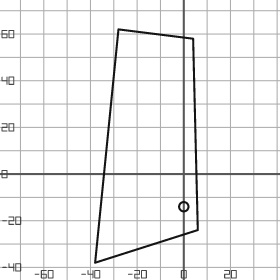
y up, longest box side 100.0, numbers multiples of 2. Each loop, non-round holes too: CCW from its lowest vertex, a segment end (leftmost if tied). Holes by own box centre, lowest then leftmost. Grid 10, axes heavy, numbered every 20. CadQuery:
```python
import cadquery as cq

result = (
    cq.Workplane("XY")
    .moveTo(-38.0, -38.0)
    .lineTo(6.0, -24.0)
    .lineTo(4.0, 58.0)
    .lineTo(-28.0, 62.0)
    .close()
    .moveTo(0.0, -14.0)
    .circle(2.0)
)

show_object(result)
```